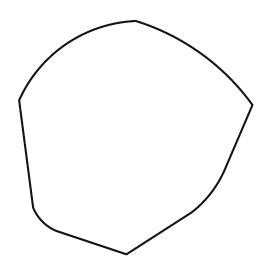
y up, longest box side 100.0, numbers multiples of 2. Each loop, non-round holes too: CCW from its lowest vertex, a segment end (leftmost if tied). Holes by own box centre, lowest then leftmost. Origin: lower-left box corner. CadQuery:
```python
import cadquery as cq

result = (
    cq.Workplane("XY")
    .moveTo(46.0, 0.0)
    .lineTo(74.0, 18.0)
    .threePointArc((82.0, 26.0), (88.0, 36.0))
    .lineTo(100.0, 64.0)
    .threePointArc((78.0, 86.0), (50.0, 100.0))
    .threePointArc((20.0, 90.0), (0.0, 66.0))
    .lineTo(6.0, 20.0)
    .threePointArc((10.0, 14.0), (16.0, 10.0))
    .close()
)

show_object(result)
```